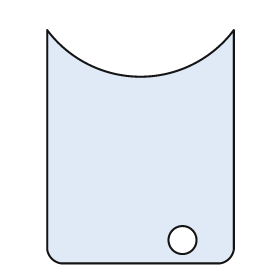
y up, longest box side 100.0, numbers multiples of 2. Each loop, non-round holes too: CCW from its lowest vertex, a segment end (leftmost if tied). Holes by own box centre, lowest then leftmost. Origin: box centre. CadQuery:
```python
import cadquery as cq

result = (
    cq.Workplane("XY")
    .moveTo(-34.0, -50.0)
    .lineTo(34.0, -50.0)
    .threePointArc((38.0, -48.0), (40.0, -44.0))
    .lineTo(40.0, 50.0)
    .threePointArc((0.0, 30.0), (-40.0, 50.0))
    .lineTo(-40.0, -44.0)
    .threePointArc((-38.0, -48.0), (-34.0, -50.0))
    .close()
    .moveTo(18.0, -40.0)
    .circle(6.0)
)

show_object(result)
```